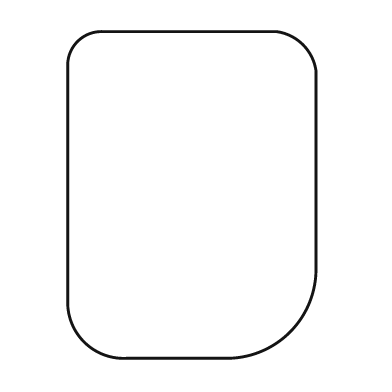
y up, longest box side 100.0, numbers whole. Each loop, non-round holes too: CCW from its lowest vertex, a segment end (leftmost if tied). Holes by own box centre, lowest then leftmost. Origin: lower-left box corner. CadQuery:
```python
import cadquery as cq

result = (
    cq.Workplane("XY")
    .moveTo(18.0, 0.0)
    .lineTo(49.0, 0.0)
    .threePointArc((68.0, 8.0), (76.0, 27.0))
    .lineTo(76.0, 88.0)
    .threePointArc((72.0, 96.0), (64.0, 100.0))
    .lineTo(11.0, 100.0)
    .threePointArc((3.0, 97.0), (0.0, 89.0))
    .lineTo(0.0, 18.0)
    .threePointArc((5.0, 5.0), (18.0, 0.0))
    .close()
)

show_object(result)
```